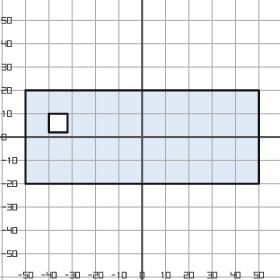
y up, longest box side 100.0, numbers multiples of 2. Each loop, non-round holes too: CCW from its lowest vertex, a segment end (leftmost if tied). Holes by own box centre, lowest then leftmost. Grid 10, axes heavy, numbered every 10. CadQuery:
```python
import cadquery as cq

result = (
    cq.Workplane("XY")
    .moveTo(-50.0, -20.0)
    .lineTo(50.0, -20.0)
    .lineTo(50.0, 20.0)
    .lineTo(-50.0, 20.0)
    .close()
    .moveTo(-40.0, 2.0)
    .lineTo(-32.0, 2.0)
    .lineTo(-32.0, 10.0)
    .lineTo(-40.0, 10.0)
    .close()
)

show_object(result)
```